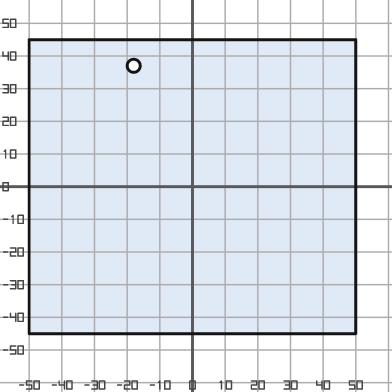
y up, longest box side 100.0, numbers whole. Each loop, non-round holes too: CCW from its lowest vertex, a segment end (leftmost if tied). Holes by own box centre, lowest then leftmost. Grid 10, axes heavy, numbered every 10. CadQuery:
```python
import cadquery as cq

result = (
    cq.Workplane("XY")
    .moveTo(-50.0, -45.0)
    .lineTo(50.0, -45.0)
    .lineTo(50.0, 45.0)
    .lineTo(-50.0, 45.0)
    .close()
    .moveTo(-18.0, 37.0)
    .circle(2.0)
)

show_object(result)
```